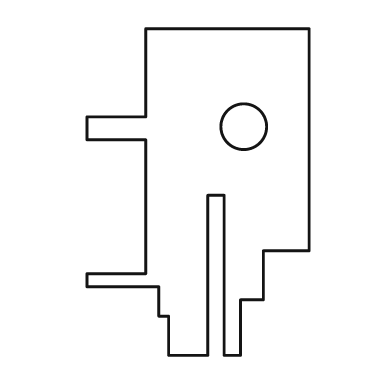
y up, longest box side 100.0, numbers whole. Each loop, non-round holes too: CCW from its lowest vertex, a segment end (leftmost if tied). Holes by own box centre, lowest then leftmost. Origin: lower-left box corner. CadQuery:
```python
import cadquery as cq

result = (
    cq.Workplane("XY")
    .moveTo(25.0, 0.0)
    .lineTo(37.0, 0.0)
    .lineTo(37.0, 49.0)
    .lineTo(42.0, 49.0)
    .lineTo(42.0, 0.0)
    .lineTo(47.0, 0.0)
    .lineTo(47.0, 17.0)
    .lineTo(54.0, 17.0)
    .lineTo(54.0, 32.0)
    .lineTo(68.0, 32.0)
    .lineTo(68.0, 100.0)
    .lineTo(18.0, 100.0)
    .lineTo(18.0, 73.0)
    .lineTo(0.0, 73.0)
    .lineTo(0.0, 66.0)
    .lineTo(18.0, 66.0)
    .lineTo(18.0, 25.0)
    .lineTo(0.0, 25.0)
    .lineTo(0.0, 21.0)
    .lineTo(22.0, 21.0)
    .lineTo(22.0, 12.0)
    .lineTo(25.0, 12.0)
    .close()
    .moveTo(48.0, 70.0)
    .circle(7.0)
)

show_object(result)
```